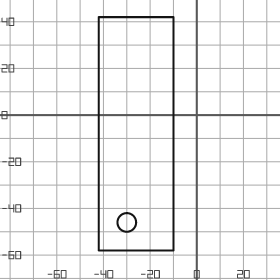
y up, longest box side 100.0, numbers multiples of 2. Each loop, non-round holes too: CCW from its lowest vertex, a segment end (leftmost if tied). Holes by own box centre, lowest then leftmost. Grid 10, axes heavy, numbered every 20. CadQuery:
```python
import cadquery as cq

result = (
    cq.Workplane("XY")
    .moveTo(-42.0, -58.0)
    .lineTo(-10.0, -58.0)
    .lineTo(-10.0, 42.0)
    .lineTo(-42.0, 42.0)
    .close()
    .moveTo(-30.0, -46.0)
    .circle(4.0)
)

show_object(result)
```